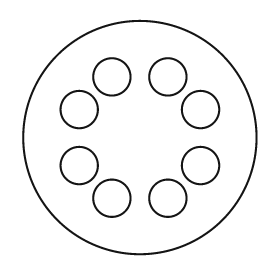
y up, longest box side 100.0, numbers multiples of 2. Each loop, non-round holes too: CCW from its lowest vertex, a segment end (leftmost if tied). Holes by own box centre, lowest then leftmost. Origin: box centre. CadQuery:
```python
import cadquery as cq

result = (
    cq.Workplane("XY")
    .moveTo(0.0, 0.0)
    .circle(50.0)
    .moveTo(-12.0, -26.0)
    .circle(8.0)
    .moveTo(12.0, -26.0)
    .circle(8.0)
    .moveTo(-26.0, -12.0)
    .circle(8.0)
    .moveTo(26.0, -12.0)
    .circle(8.0)
    .moveTo(-26.0, 12.0)
    .circle(8.0)
    .moveTo(26.0, 12.0)
    .circle(8.0)
    .moveTo(-12.0, 26.0)
    .circle(8.0)
    .moveTo(12.0, 26.0)
    .circle(8.0)
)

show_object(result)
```